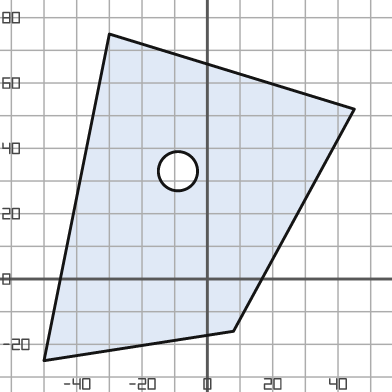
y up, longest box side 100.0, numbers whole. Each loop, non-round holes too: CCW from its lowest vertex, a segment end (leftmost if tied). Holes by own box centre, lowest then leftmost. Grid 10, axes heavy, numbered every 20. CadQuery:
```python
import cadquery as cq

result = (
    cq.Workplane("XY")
    .moveTo(-50.0, -25.0)
    .lineTo(8.0, -16.0)
    .lineTo(45.0, 52.0)
    .lineTo(-30.0, 75.0)
    .close()
    .moveTo(-9.0, 33.0)
    .circle(6.0)
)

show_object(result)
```